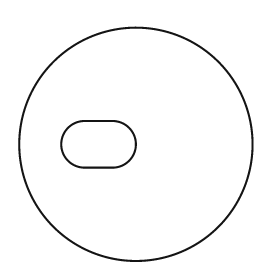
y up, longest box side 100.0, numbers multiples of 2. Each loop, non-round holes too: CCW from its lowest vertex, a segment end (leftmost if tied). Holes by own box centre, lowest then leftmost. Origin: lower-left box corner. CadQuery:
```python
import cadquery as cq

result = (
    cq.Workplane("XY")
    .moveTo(50.0, 50.0)
    .circle(50.0)
    .moveTo(28.0, 40.0)
    .lineTo(40.0, 40.0)
    .threePointArc((50.0, 50.0), (40.0, 60.0))
    .lineTo(28.0, 60.0)
    .threePointArc((18.0, 50.0), (28.0, 40.0))
    .close()
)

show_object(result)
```